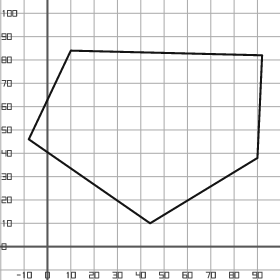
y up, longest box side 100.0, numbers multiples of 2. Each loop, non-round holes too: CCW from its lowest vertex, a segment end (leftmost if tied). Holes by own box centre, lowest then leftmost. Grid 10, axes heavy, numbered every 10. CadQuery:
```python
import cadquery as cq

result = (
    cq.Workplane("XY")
    .moveTo(44.0, 10.0)
    .lineTo(90.0, 38.0)
    .lineTo(92.0, 82.0)
    .lineTo(10.0, 84.0)
    .lineTo(-8.0, 46.0)
    .close()
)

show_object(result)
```